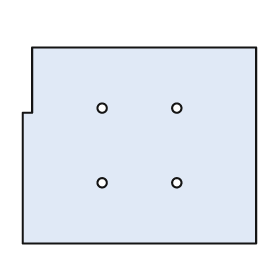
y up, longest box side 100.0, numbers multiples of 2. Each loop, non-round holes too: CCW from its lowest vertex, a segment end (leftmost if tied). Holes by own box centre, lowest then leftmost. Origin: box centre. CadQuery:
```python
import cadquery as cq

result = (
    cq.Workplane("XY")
    .moveTo(-50.0, -42.0)
    .lineTo(50.0, -42.0)
    .lineTo(50.0, 42.0)
    .lineTo(-46.0, 42.0)
    .lineTo(-46.0, 14.0)
    .lineTo(-50.0, 14.0)
    .close()
    .moveTo(-16.0, -16.0)
    .circle(2.0)
    .moveTo(16.0, -16.0)
    .circle(2.0)
    .moveTo(-16.0, 16.0)
    .circle(2.0)
    .moveTo(16.0, 16.0)
    .circle(2.0)
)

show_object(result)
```